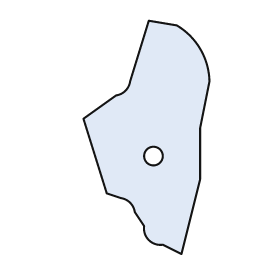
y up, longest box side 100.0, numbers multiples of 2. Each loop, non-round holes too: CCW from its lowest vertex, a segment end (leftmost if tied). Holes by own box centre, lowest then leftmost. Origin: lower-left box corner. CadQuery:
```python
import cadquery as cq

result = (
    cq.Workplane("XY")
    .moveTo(42.0, 0.0)
    .lineTo(50.0, 32.0)
    .lineTo(50.0, 54.0)
    .lineTo(54.0, 74.0)
    .threePointArc((50.0, 88.0), (40.0, 98.0))
    .lineTo(28.0, 100.0)
    .lineTo(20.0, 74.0)
    .threePointArc((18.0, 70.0), (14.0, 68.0))
    .lineTo(0.0, 58.0)
    .lineTo(10.0, 26.0)
    .lineTo(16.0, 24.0)
    .threePointArc((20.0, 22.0), (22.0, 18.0))
    .lineTo(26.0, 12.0)
    .threePointArc((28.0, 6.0), (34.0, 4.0))
    .close()
    .moveTo(30.0, 42.0)
    .circle(4.0)
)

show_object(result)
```